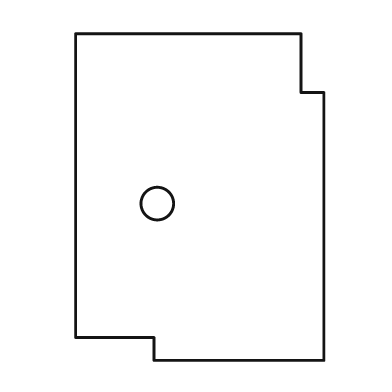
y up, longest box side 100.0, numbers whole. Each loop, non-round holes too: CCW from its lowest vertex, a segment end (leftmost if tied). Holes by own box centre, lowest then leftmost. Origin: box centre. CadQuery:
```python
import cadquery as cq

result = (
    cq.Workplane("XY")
    .moveTo(-14.0, -50.0)
    .lineTo(38.0, -50.0)
    .lineTo(38.0, 32.0)
    .lineTo(31.0, 32.0)
    .lineTo(31.0, 50.0)
    .lineTo(-38.0, 50.0)
    .lineTo(-38.0, -43.0)
    .lineTo(-14.0, -43.0)
    .close()
    .moveTo(-13.0, -2.0)
    .circle(5.0)
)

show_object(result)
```